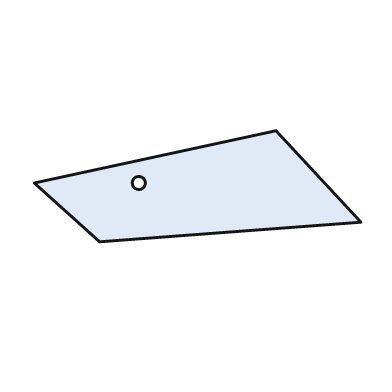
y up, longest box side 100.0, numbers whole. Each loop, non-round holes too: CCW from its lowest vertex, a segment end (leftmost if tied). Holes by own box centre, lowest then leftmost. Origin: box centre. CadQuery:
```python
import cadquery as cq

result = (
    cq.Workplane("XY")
    .moveTo(-30.0, -17.0)
    .lineTo(50.0, -11.0)
    .lineTo(24.0, 17.0)
    .lineTo(-50.0, 1.0)
    .close()
    .moveTo(-18.0, 1.0)
    .circle(2.0)
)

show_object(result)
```